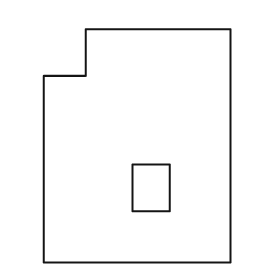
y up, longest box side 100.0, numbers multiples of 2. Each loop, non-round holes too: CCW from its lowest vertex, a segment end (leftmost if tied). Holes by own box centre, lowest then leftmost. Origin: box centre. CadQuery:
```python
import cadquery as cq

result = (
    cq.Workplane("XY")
    .moveTo(-40.0, -50.0)
    .lineTo(40.0, -50.0)
    .lineTo(40.0, 50.0)
    .lineTo(-22.0, 50.0)
    .lineTo(-22.0, 30.0)
    .lineTo(-40.0, 30.0)
    .close()
    .moveTo(-2.0, -28.0)
    .lineTo(14.0, -28.0)
    .lineTo(14.0, -8.0)
    .lineTo(-2.0, -8.0)
    .close()
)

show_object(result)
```